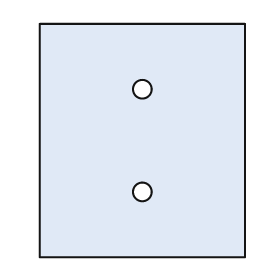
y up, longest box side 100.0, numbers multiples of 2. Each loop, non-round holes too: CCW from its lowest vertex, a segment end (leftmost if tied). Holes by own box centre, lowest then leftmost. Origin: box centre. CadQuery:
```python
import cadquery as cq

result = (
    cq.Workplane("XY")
    .moveTo(-44.0, -50.0)
    .lineTo(44.0, -50.0)
    .lineTo(44.0, 50.0)
    .lineTo(-44.0, 50.0)
    .close()
    .moveTo(0.0, -22.0)
    .circle(4.0)
    .moveTo(0.0, 22.0)
    .circle(4.0)
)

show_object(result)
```